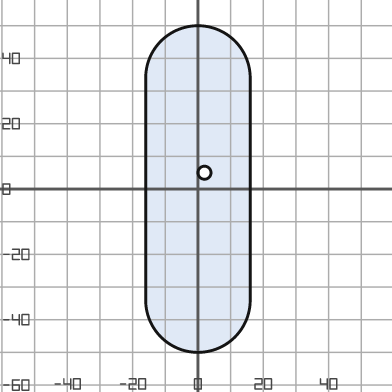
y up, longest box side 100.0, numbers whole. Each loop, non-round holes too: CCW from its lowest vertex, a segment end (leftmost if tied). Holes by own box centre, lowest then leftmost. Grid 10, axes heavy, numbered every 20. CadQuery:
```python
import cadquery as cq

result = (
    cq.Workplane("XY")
    .moveTo(-16.0, -34.0)
    .threePointArc((0.0, -50.0), (16.0, -34.0))
    .lineTo(16.0, 34.0)
    .threePointArc((0.0, 50.0), (-16.0, 34.0))
    .close()
    .moveTo(2.0, 5.0)
    .circle(2.0)
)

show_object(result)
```